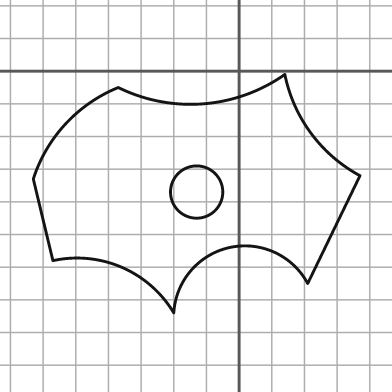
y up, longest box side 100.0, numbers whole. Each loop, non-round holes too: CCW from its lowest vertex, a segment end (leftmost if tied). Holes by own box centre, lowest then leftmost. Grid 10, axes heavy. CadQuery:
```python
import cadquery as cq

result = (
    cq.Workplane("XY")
    .moveTo(-20.0, -74.0)
    .threePointArc((-3.0, -54.0), (21.0, -65.0))
    .lineTo(37.0, -32.0)
    .threePointArc((22.0, -19.0), (14.0, -1.0))
    .threePointArc((-11.0, -10.0), (-37.0, -5.0))
    .threePointArc((-53.0, -16.0), (-63.0, -33.0))
    .lineTo(-57.0, -58.0)
    .threePointArc((-36.0, -60.0), (-20.0, -74.0))
    .close()
    .moveTo(-13.0, -37.0)
    .circle(8.0)
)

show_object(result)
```